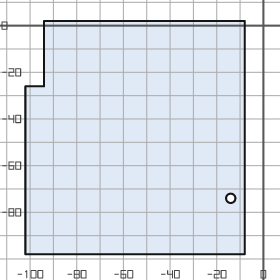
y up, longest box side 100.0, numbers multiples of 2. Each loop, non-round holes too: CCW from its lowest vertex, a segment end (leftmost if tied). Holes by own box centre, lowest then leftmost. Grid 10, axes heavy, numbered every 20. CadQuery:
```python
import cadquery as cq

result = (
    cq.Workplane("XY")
    .moveTo(-102.0, -98.0)
    .lineTo(-8.0, -98.0)
    .lineTo(-8.0, 2.0)
    .lineTo(-94.0, 2.0)
    .lineTo(-94.0, -26.0)
    .lineTo(-102.0, -26.0)
    .close()
    .moveTo(-14.0, -74.0)
    .circle(2.0)
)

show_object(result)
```